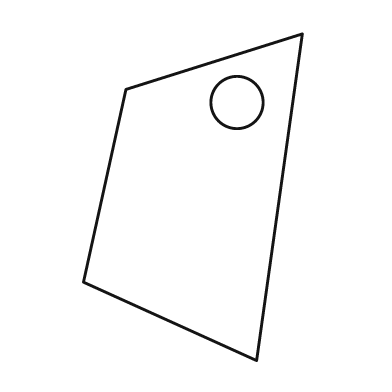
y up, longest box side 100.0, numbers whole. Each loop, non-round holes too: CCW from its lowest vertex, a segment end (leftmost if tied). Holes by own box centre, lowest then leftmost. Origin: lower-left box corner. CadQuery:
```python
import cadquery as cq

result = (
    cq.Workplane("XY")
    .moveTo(53.0, 0.0)
    .lineTo(67.0, 100.0)
    .lineTo(13.0, 83.0)
    .lineTo(0.0, 24.0)
    .close()
    .moveTo(47.0, 79.0)
    .circle(8.0)
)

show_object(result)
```